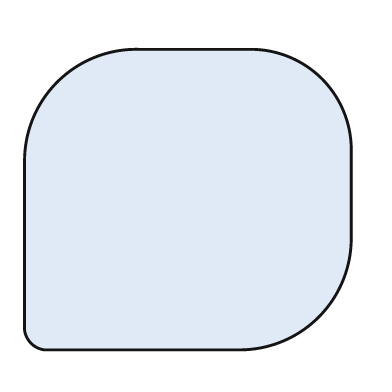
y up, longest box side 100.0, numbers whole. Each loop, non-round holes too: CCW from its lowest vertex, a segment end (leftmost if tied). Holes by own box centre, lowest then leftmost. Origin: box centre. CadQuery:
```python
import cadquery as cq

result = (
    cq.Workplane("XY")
    .moveTo(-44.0, -46.0)
    .lineTo(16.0, -46.0)
    .threePointArc((40.0, -36.0), (50.0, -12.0))
    .lineTo(50.0, 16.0)
    .threePointArc((41.0, 37.0), (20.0, 46.0))
    .lineTo(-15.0, 46.0)
    .threePointArc((-40.0, 36.0), (-50.0, 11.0))
    .lineTo(-50.0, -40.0)
    .threePointArc((-48.0, -44.0), (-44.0, -46.0))
    .close()
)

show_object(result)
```